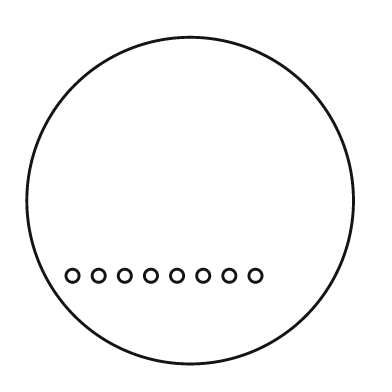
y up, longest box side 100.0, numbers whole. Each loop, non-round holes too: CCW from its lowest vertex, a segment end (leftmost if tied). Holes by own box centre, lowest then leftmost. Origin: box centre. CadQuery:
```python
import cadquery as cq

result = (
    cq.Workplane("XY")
    .moveTo(0.0, 0.0)
    .circle(50.0)
    .moveTo(-36.0, -23.0)
    .circle(2.0)
    .moveTo(-28.0, -23.0)
    .circle(2.0)
    .moveTo(-20.0, -23.0)
    .circle(2.0)
    .moveTo(-12.0, -23.0)
    .circle(2.0)
    .moveTo(-4.0, -23.0)
    .circle(2.0)
    .moveTo(4.0, -23.0)
    .circle(2.0)
    .moveTo(12.0, -23.0)
    .circle(2.0)
    .moveTo(20.0, -23.0)
    .circle(2.0)
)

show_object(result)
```